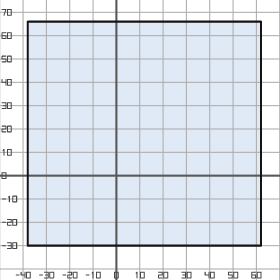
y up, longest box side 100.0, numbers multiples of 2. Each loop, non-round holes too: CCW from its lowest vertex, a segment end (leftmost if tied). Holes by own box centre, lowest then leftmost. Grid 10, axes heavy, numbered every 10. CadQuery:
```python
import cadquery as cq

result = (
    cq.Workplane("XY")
    .moveTo(-38.0, -30.0)
    .lineTo(62.0, -30.0)
    .lineTo(62.0, 66.0)
    .lineTo(-38.0, 66.0)
    .close()
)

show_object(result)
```